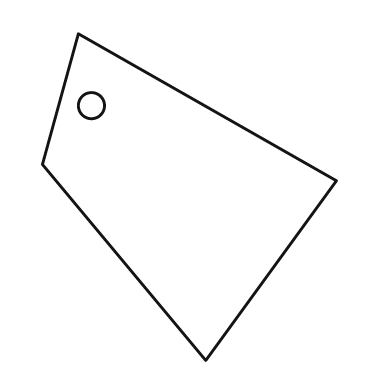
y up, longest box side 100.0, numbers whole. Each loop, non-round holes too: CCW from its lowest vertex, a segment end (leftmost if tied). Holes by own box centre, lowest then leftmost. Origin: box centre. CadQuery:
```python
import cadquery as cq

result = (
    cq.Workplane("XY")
    .moveTo(5.0, -50.0)
    .lineTo(45.0, 5.0)
    .lineTo(-34.0, 50.0)
    .lineTo(-45.0, 10.0)
    .close()
    .moveTo(-30.0, 28.0)
    .circle(4.0)
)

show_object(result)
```